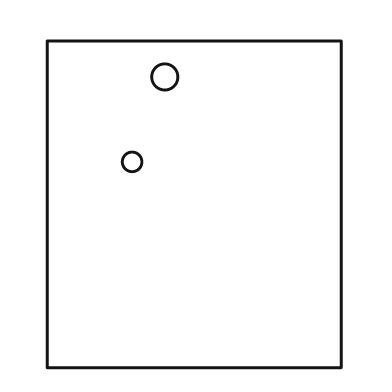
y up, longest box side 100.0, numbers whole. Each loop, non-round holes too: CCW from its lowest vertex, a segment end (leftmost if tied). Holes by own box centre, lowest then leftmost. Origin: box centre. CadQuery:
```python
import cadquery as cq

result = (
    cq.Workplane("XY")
    .moveTo(-45.0, -50.0)
    .lineTo(45.0, -50.0)
    .lineTo(45.0, 50.0)
    .lineTo(-45.0, 50.0)
    .close()
    .moveTo(-19.0, 13.0)
    .circle(3.0)
    .moveTo(-9.0, 39.0)
    .circle(4.0)
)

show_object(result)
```